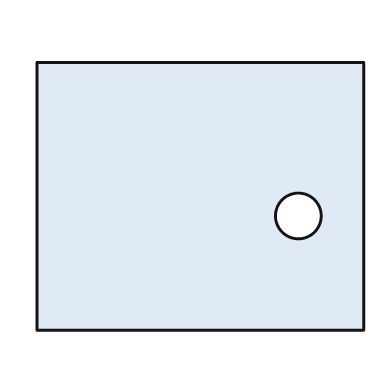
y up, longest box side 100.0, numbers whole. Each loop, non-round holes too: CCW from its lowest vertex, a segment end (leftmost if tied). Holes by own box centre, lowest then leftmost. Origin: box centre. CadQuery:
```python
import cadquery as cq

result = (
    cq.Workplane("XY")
    .moveTo(-50.0, -41.0)
    .lineTo(50.0, -41.0)
    .lineTo(50.0, 41.0)
    .lineTo(-50.0, 41.0)
    .close()
    .moveTo(30.0, -6.0)
    .circle(7.0)
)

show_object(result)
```